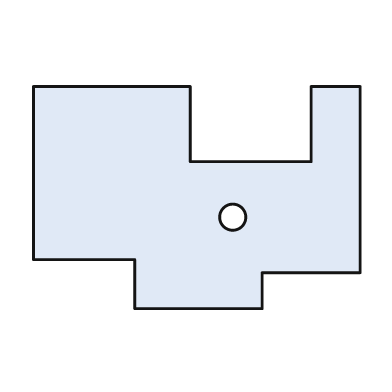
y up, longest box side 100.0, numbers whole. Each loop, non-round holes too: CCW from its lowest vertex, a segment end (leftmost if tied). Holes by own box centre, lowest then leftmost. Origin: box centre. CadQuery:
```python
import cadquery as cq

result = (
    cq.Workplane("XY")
    .moveTo(-19.0, -34.0)
    .lineTo(20.0, -34.0)
    .lineTo(20.0, -23.0)
    .lineTo(50.0, -23.0)
    .lineTo(50.0, 34.0)
    .lineTo(35.0, 34.0)
    .lineTo(35.0, 11.0)
    .lineTo(-2.0, 11.0)
    .lineTo(-2.0, 34.0)
    .lineTo(-50.0, 34.0)
    .lineTo(-50.0, -19.0)
    .lineTo(-19.0, -19.0)
    .close()
    .moveTo(11.0, -6.0)
    .circle(4.0)
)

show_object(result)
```